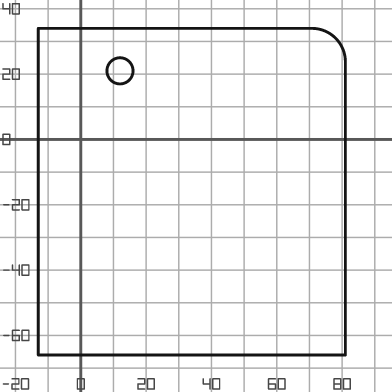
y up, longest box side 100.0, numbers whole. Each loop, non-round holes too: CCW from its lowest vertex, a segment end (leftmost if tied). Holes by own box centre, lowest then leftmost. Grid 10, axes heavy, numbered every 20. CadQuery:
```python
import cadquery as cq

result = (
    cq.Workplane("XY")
    .moveTo(-13.0, -66.0)
    .lineTo(81.0, -66.0)
    .lineTo(81.0, 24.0)
    .threePointArc((78.0, 31.0), (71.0, 34.0))
    .lineTo(-13.0, 34.0)
    .close()
    .moveTo(12.0, 21.0)
    .circle(4.0)
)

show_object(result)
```